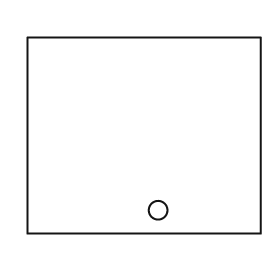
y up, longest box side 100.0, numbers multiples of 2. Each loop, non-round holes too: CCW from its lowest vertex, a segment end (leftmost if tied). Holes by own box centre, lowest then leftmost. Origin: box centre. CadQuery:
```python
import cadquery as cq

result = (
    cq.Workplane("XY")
    .moveTo(-50.0, -42.0)
    .lineTo(50.0, -42.0)
    .lineTo(50.0, 42.0)
    .lineTo(-50.0, 42.0)
    .close()
    .moveTo(6.0, -32.0)
    .circle(4.0)
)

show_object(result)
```